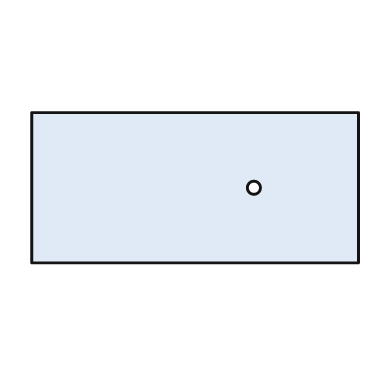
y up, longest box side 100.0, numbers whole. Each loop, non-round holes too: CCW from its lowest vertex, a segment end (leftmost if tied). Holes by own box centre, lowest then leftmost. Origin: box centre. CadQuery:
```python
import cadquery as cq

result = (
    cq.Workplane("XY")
    .moveTo(-50.0, -23.0)
    .lineTo(50.0, -23.0)
    .lineTo(50.0, 23.0)
    .lineTo(-50.0, 23.0)
    .close()
    .moveTo(18.0, 0.0)
    .circle(2.0)
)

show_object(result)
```